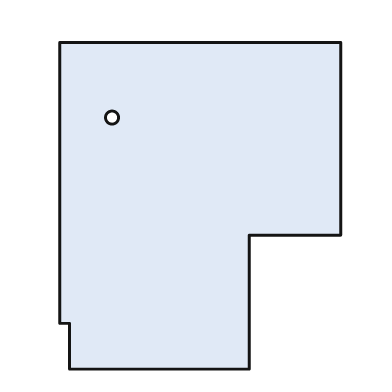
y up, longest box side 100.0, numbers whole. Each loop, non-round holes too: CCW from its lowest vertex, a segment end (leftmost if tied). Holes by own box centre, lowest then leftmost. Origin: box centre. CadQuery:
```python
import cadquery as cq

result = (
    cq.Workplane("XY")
    .moveTo(-40.0, -50.0)
    .lineTo(15.0, -50.0)
    .lineTo(15.0, -9.0)
    .lineTo(43.0, -9.0)
    .lineTo(43.0, 50.0)
    .lineTo(-43.0, 50.0)
    .lineTo(-43.0, -36.0)
    .lineTo(-40.0, -36.0)
    .close()
    .moveTo(-27.0, 27.0)
    .circle(2.0)
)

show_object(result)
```